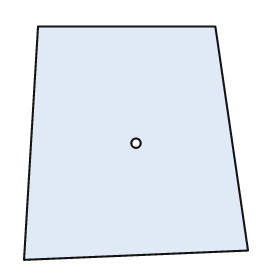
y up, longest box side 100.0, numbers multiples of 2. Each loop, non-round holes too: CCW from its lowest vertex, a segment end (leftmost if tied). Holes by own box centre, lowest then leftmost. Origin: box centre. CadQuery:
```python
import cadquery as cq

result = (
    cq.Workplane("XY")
    .moveTo(-48.0, -50.0)
    .lineTo(48.0, -46.0)
    .lineTo(34.0, 50.0)
    .lineTo(-42.0, 50.0)
    .close()
    .moveTo(0.0, 0.0)
    .circle(2.0)
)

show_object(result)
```